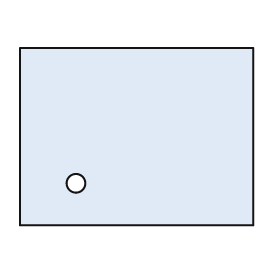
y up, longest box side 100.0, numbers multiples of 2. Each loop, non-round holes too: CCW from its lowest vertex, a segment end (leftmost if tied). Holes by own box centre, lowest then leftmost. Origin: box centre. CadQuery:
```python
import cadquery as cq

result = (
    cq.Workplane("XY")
    .moveTo(-50.0, -38.0)
    .lineTo(50.0, -38.0)
    .lineTo(50.0, 38.0)
    .lineTo(-50.0, 38.0)
    .close()
    .moveTo(-26.0, -20.0)
    .circle(4.0)
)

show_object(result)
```